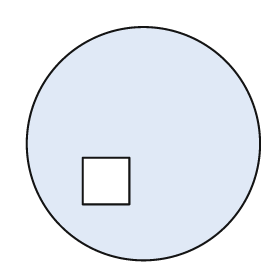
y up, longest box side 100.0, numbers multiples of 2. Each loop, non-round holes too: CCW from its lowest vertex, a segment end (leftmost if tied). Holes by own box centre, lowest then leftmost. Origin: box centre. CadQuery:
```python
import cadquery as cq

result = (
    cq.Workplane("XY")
    .moveTo(0.0, 0.0)
    .circle(50.0)
    .moveTo(-26.0, -26.0)
    .lineTo(-6.0, -26.0)
    .lineTo(-6.0, -6.0)
    .lineTo(-26.0, -6.0)
    .close()
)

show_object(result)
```